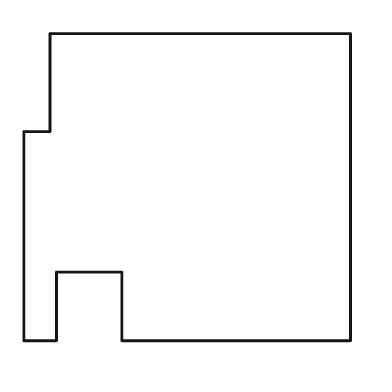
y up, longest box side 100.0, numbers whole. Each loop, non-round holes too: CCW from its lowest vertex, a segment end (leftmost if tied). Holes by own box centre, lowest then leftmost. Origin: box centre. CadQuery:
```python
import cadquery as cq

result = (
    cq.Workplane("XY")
    .moveTo(-50.0, -47.0)
    .lineTo(-40.0, -47.0)
    .lineTo(-40.0, -26.0)
    .lineTo(-20.0, -26.0)
    .lineTo(-20.0, -47.0)
    .lineTo(50.0, -47.0)
    .lineTo(50.0, 47.0)
    .lineTo(-42.0, 47.0)
    .lineTo(-42.0, 17.0)
    .lineTo(-50.0, 17.0)
    .close()
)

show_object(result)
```